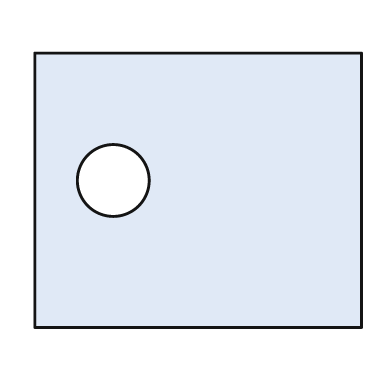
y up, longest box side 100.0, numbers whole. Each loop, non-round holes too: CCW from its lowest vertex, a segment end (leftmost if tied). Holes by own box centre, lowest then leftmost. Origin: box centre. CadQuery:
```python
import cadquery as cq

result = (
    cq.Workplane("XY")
    .moveTo(-50.0, -42.0)
    .lineTo(50.0, -42.0)
    .lineTo(50.0, 42.0)
    .lineTo(-50.0, 42.0)
    .close()
    .moveTo(-26.0, 3.0)
    .circle(11.0)
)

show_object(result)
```